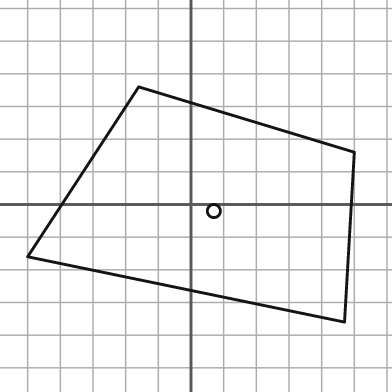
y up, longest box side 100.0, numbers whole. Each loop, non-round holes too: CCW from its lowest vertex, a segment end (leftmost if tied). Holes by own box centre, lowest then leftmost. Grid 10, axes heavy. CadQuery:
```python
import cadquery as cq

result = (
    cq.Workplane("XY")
    .moveTo(47.0, -36.0)
    .lineTo(50.0, 16.0)
    .lineTo(-16.0, 36.0)
    .lineTo(-50.0, -16.0)
    .close()
    .moveTo(7.0, -2.0)
    .circle(2.0)
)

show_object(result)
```